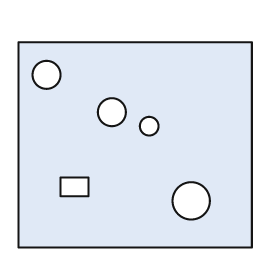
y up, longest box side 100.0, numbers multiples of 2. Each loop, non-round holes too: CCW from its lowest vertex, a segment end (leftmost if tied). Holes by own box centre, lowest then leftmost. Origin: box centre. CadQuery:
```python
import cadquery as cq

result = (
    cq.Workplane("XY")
    .moveTo(-50.0, -44.0)
    .lineTo(50.0, -44.0)
    .lineTo(50.0, 44.0)
    .lineTo(-50.0, 44.0)
    .close()
    .moveTo(24.0, -24.0)
    .circle(8.0)
    .moveTo(-32.0, -22.0)
    .lineTo(-20.0, -22.0)
    .lineTo(-20.0, -14.0)
    .lineTo(-32.0, -14.0)
    .close()
    .moveTo(6.0, 8.0)
    .circle(4.0)
    .moveTo(-10.0, 14.0)
    .circle(6.0)
    .moveTo(-38.0, 30.0)
    .circle(6.0)
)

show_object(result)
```